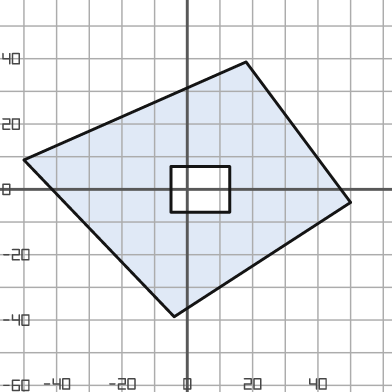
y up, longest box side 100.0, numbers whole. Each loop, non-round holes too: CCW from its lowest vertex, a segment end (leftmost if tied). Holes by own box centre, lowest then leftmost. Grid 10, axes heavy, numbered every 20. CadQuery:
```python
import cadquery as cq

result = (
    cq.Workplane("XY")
    .moveTo(-4.0, -39.0)
    .lineTo(50.0, -4.0)
    .lineTo(18.0, 39.0)
    .lineTo(-50.0, 9.0)
    .close()
    .moveTo(-5.0, -7.0)
    .lineTo(13.0, -7.0)
    .lineTo(13.0, 7.0)
    .lineTo(-5.0, 7.0)
    .close()
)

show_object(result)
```